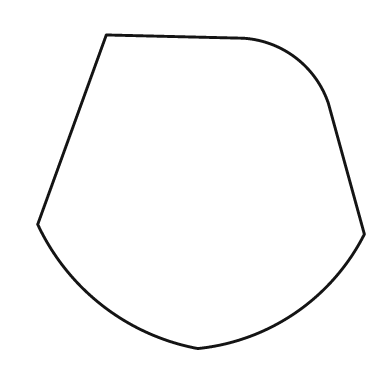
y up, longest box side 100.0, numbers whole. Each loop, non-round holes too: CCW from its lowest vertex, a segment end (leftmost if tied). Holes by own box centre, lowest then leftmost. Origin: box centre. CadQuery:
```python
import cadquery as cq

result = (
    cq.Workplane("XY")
    .moveTo(-1.0, -48.0)
    .threePointArc((29.0, -37.0), (50.0, -13.0))
    .lineTo(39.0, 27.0)
    .threePointArc((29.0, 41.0), (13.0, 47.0))
    .lineTo(-29.0, 48.0)
    .lineTo(-50.0, -10.0)
    .threePointArc((-30.0, -35.0), (-1.0, -48.0))
    .close()
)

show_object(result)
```